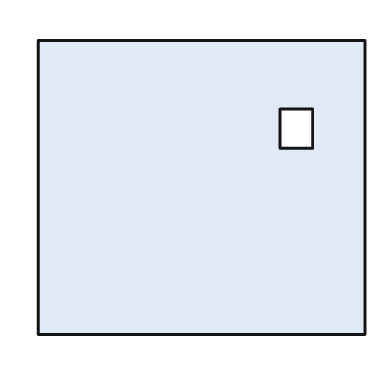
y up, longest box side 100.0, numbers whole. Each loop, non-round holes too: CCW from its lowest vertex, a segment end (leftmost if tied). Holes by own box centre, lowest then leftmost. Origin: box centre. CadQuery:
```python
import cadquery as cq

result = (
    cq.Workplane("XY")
    .moveTo(-50.0, -45.0)
    .lineTo(50.0, -45.0)
    .lineTo(50.0, 45.0)
    .lineTo(-50.0, 45.0)
    .close()
    .moveTo(24.0, 12.0)
    .lineTo(34.0, 12.0)
    .lineTo(34.0, 24.0)
    .lineTo(24.0, 24.0)
    .close()
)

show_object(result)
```